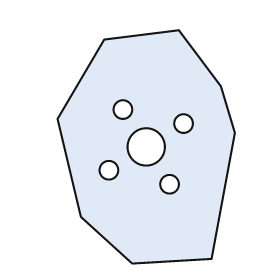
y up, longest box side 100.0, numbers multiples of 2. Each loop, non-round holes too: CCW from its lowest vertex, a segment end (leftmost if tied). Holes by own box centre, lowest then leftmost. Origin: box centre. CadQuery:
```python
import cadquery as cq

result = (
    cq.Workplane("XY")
    .moveTo(-6.0, -50.0)
    .lineTo(28.0, -48.0)
    .lineTo(38.0, 6.0)
    .lineTo(32.0, 26.0)
    .lineTo(14.0, 50.0)
    .lineTo(-18.0, 46.0)
    .lineTo(-38.0, 12.0)
    .lineTo(-28.0, -30.0)
    .close()
    .moveTo(10.0, -16.0)
    .circle(4.0)
    .moveTo(-16.0, -10.0)
    .circle(4.0)
    .moveTo(0.0, 0.0)
    .circle(8.0)
    .moveTo(16.0, 10.0)
    .circle(4.0)
    .moveTo(-10.0, 16.0)
    .circle(4.0)
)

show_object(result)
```